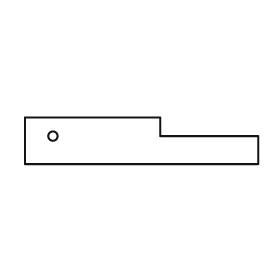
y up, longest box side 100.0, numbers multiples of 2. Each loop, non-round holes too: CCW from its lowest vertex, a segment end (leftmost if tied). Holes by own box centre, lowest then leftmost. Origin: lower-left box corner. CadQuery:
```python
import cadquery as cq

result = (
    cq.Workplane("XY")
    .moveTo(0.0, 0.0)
    .lineTo(100.0, 0.0)
    .lineTo(100.0, 12.0)
    .lineTo(58.0, 12.0)
    .lineTo(58.0, 20.0)
    .lineTo(0.0, 20.0)
    .close()
    .moveTo(12.0, 12.0)
    .circle(2.0)
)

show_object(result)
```